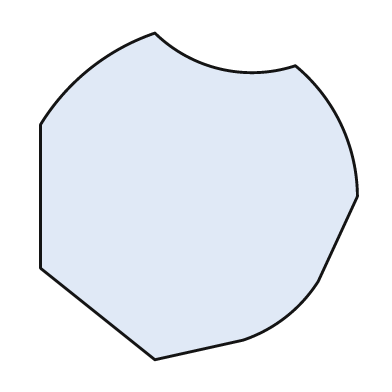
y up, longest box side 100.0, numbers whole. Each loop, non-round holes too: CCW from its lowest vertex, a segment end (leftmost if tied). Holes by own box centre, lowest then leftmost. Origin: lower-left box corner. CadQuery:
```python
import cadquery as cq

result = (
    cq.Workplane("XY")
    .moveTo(35.0, 0.0)
    .lineTo(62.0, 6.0)
    .threePointArc((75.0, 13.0), (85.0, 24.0))
    .lineTo(97.0, 50.0)
    .threePointArc((92.0, 72.0), (78.0, 90.0))
    .threePointArc((55.0, 89.0), (35.0, 100.0))
    .threePointArc((15.0, 89.0), (0.0, 72.0))
    .lineTo(0.0, 28.0)
    .close()
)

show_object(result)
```